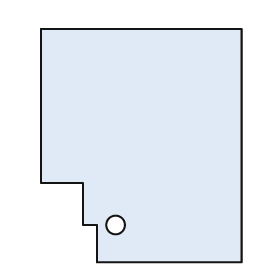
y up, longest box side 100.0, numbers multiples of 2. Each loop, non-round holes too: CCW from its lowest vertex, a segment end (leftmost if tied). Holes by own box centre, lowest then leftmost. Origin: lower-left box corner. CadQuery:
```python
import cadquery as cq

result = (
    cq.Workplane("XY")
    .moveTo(24.0, 0.0)
    .lineTo(86.0, 0.0)
    .lineTo(86.0, 100.0)
    .lineTo(0.0, 100.0)
    .lineTo(0.0, 34.0)
    .lineTo(18.0, 34.0)
    .lineTo(18.0, 16.0)
    .lineTo(24.0, 16.0)
    .close()
    .moveTo(32.0, 16.0)
    .circle(4.0)
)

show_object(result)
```